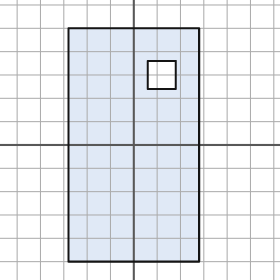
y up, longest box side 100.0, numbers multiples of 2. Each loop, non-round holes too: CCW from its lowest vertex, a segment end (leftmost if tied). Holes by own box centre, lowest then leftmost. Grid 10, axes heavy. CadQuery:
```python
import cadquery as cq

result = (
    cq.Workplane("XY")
    .moveTo(-28.0, -50.0)
    .lineTo(28.0, -50.0)
    .lineTo(28.0, 50.0)
    .lineTo(-28.0, 50.0)
    .close()
    .moveTo(6.0, 24.0)
    .lineTo(18.0, 24.0)
    .lineTo(18.0, 36.0)
    .lineTo(6.0, 36.0)
    .close()
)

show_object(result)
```